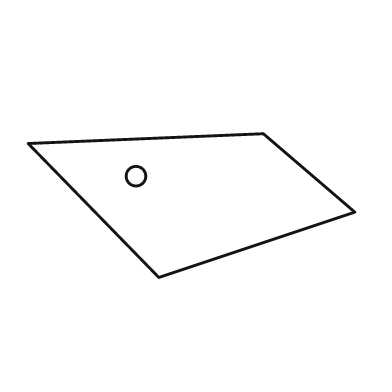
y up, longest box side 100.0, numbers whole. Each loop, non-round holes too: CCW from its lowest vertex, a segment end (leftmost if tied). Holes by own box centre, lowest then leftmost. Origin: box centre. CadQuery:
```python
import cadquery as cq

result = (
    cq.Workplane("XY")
    .moveTo(-10.0, -22.0)
    .lineTo(50.0, -2.0)
    .lineTo(22.0, 22.0)
    .lineTo(-50.0, 19.0)
    .close()
    .moveTo(-17.0, 9.0)
    .circle(3.0)
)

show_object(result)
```